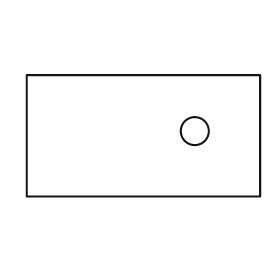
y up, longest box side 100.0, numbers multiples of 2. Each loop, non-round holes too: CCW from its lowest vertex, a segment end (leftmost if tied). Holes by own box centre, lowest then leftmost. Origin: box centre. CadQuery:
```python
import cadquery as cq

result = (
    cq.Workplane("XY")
    .moveTo(-50.0, -26.0)
    .lineTo(50.0, -26.0)
    .lineTo(50.0, 26.0)
    .lineTo(-50.0, 26.0)
    .close()
    .moveTo(22.0, 2.0)
    .circle(6.0)
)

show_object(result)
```